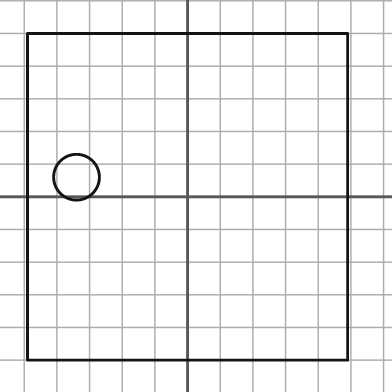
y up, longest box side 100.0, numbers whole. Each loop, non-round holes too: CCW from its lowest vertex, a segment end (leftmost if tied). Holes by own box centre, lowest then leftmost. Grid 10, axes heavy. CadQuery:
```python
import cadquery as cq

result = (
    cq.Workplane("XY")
    .moveTo(-49.0, -50.0)
    .lineTo(49.0, -50.0)
    .lineTo(49.0, 50.0)
    .lineTo(-49.0, 50.0)
    .close()
    .moveTo(-34.0, 6.0)
    .circle(7.0)
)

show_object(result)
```